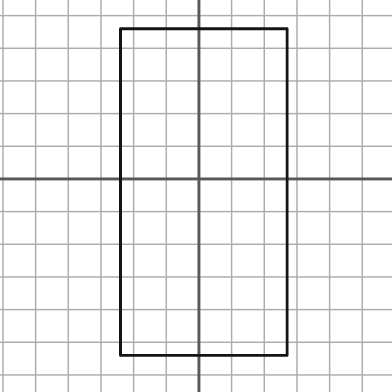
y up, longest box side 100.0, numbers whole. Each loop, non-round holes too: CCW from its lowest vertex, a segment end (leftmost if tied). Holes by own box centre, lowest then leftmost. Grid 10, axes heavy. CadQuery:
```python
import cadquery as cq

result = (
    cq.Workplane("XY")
    .moveTo(-24.0, -54.0)
    .lineTo(27.0, -54.0)
    .lineTo(27.0, 46.0)
    .lineTo(-24.0, 46.0)
    .close()
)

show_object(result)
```